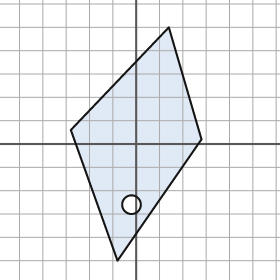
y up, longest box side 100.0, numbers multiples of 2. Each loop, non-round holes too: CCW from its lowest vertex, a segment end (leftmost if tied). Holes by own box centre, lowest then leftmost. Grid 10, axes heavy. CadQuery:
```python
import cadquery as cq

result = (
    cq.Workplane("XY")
    .moveTo(-8.0, -50.0)
    .lineTo(28.0, 2.0)
    .lineTo(14.0, 50.0)
    .lineTo(-28.0, 6.0)
    .close()
    .moveTo(-2.0, -26.0)
    .circle(4.0)
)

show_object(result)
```